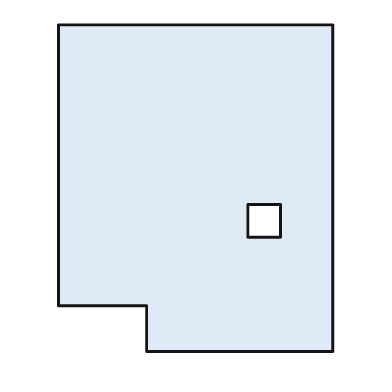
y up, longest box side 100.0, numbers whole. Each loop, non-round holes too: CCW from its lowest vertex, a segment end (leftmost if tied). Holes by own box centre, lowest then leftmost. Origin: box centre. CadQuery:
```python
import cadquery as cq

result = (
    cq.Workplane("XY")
    .moveTo(-15.0, -50.0)
    .lineTo(42.0, -50.0)
    .lineTo(42.0, 50.0)
    .lineTo(-42.0, 50.0)
    .lineTo(-42.0, -36.0)
    .lineTo(-15.0, -36.0)
    .close()
    .moveTo(16.0, -15.0)
    .lineTo(26.0, -15.0)
    .lineTo(26.0, -5.0)
    .lineTo(16.0, -5.0)
    .close()
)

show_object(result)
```